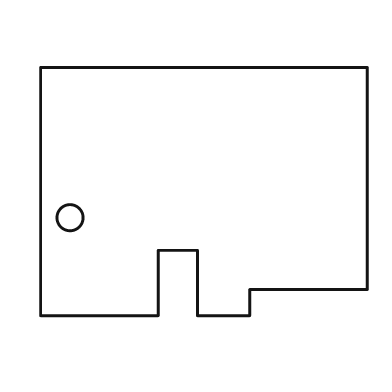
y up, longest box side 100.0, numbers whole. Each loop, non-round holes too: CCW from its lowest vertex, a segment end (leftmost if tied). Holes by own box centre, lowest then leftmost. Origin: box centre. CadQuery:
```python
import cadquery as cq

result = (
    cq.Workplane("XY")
    .moveTo(-50.0, -38.0)
    .lineTo(-14.0, -38.0)
    .lineTo(-14.0, -18.0)
    .lineTo(-2.0, -18.0)
    .lineTo(-2.0, -38.0)
    .lineTo(14.0, -38.0)
    .lineTo(14.0, -30.0)
    .lineTo(50.0, -30.0)
    .lineTo(50.0, 38.0)
    .lineTo(-50.0, 38.0)
    .close()
    .moveTo(-41.0, -8.0)
    .circle(4.0)
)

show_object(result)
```